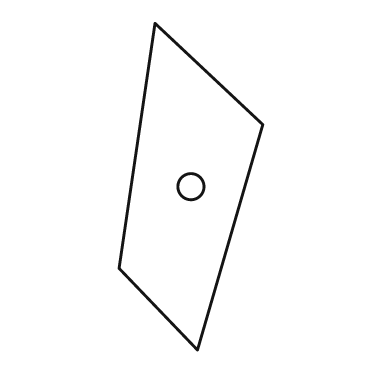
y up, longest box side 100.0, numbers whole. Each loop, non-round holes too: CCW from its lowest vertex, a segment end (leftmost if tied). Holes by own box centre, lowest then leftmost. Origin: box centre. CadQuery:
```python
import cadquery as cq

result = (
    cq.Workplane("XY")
    .moveTo(2.0, -50.0)
    .lineTo(22.0, 19.0)
    .lineTo(-11.0, 50.0)
    .lineTo(-22.0, -25.0)
    .close()
    .moveTo(0.0, 0.0)
    .circle(4.0)
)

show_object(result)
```